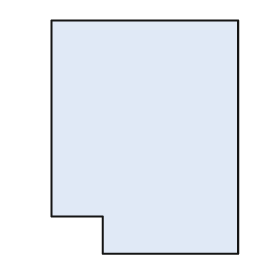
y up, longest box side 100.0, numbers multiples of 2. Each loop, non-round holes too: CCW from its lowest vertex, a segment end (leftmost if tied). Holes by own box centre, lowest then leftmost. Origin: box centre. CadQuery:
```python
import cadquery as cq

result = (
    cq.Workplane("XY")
    .moveTo(-18.0, -50.0)
    .lineTo(40.0, -50.0)
    .lineTo(40.0, 50.0)
    .lineTo(-40.0, 50.0)
    .lineTo(-40.0, -34.0)
    .lineTo(-18.0, -34.0)
    .close()
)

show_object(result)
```